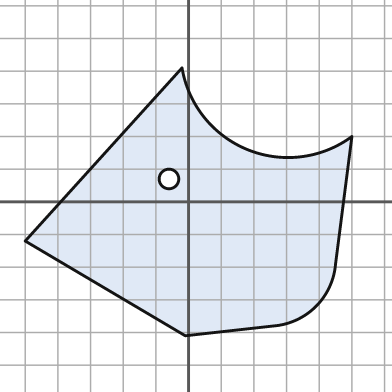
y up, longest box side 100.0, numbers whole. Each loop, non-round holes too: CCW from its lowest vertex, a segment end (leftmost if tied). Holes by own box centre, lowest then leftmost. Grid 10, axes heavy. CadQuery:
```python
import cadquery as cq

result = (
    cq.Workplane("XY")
    .moveTo(-1.0, -41.0)
    .lineTo(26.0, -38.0)
    .threePointArc((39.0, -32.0), (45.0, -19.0))
    .lineTo(50.0, 20.0)
    .threePointArc((18.0, 16.0), (-2.0, 41.0))
    .lineTo(-50.0, -12.0)
    .close()
    .moveTo(-6.0, 7.0)
    .circle(3.0)
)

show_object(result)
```